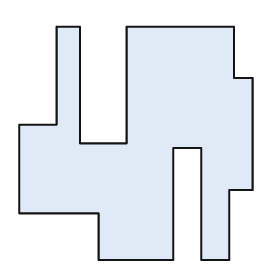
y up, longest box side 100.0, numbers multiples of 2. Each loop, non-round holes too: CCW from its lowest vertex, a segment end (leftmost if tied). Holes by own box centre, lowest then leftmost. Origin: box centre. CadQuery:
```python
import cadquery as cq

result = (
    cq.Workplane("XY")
    .moveTo(-16.0, -50.0)
    .lineTo(16.0, -50.0)
    .lineTo(16.0, -2.0)
    .lineTo(28.0, -2.0)
    .lineTo(28.0, -50.0)
    .lineTo(40.0, -50.0)
    .lineTo(40.0, -20.0)
    .lineTo(50.0, -20.0)
    .lineTo(50.0, 28.0)
    .lineTo(42.0, 28.0)
    .lineTo(42.0, 50.0)
    .lineTo(-4.0, 50.0)
    .lineTo(-4.0, 0.0)
    .lineTo(-24.0, 0.0)
    .lineTo(-24.0, 50.0)
    .lineTo(-34.0, 50.0)
    .lineTo(-34.0, 8.0)
    .lineTo(-50.0, 8.0)
    .lineTo(-50.0, -30.0)
    .lineTo(-16.0, -30.0)
    .close()
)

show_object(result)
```